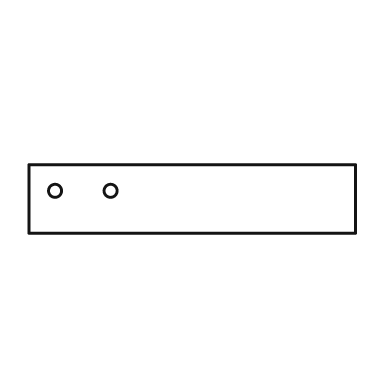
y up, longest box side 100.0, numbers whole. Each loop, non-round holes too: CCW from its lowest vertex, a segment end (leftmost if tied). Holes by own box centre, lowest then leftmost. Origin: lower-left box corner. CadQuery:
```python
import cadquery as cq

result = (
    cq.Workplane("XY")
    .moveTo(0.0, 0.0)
    .lineTo(100.0, 0.0)
    .lineTo(100.0, 21.0)
    .lineTo(0.0, 21.0)
    .close()
    .moveTo(8.0, 13.0)
    .circle(2.0)
    .moveTo(25.0, 13.0)
    .circle(2.0)
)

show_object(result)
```